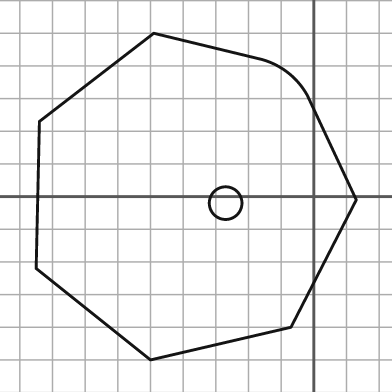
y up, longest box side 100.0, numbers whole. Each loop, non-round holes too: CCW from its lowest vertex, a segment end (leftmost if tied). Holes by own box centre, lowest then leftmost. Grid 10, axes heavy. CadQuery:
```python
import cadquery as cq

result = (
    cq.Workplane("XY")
    .moveTo(-50.0, -50.0)
    .lineTo(-7.0, -40.0)
    .lineTo(13.0, -1.0)
    .lineTo(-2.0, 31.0)
    .threePointArc((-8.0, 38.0), (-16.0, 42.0))
    .lineTo(-49.0, 50.0)
    .lineTo(-84.0, 23.0)
    .lineTo(-85.0, -22.0)
    .close()
    .moveTo(-27.0, -2.0)
    .circle(5.0)
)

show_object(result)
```